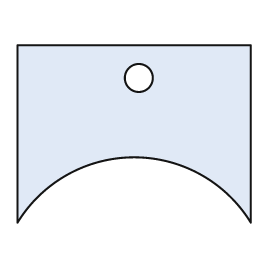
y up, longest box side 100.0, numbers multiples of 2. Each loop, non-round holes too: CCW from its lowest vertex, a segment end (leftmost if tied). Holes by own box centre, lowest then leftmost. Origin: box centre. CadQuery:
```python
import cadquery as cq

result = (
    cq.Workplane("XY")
    .moveTo(-50.0, -38.0)
    .threePointArc((0.0, -10.0), (50.0, -38.0))
    .lineTo(50.0, 38.0)
    .lineTo(-50.0, 38.0)
    .close()
    .moveTo(2.0, 24.0)
    .circle(6.0)
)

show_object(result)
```